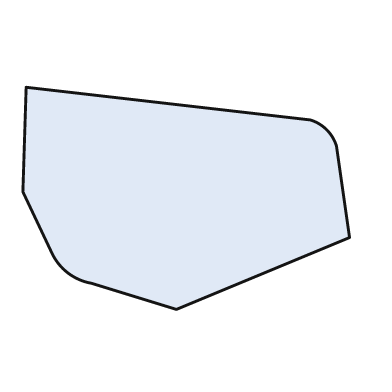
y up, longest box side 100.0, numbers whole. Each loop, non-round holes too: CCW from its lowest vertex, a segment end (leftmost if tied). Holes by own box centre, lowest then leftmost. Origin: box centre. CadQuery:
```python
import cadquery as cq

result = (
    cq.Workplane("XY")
    .moveTo(-3.0, -34.0)
    .lineTo(50.0, -12.0)
    .lineTo(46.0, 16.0)
    .threePointArc((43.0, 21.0), (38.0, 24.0))
    .lineTo(-49.0, 34.0)
    .lineTo(-50.0, 2.0)
    .lineTo(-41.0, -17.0)
    .threePointArc((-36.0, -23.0), (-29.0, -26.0))
    .close()
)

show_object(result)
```